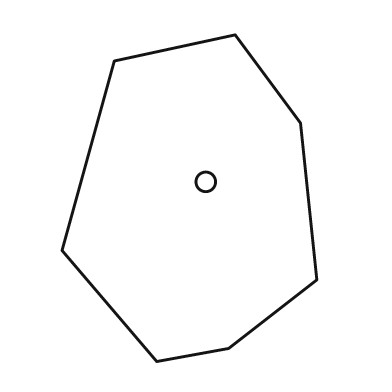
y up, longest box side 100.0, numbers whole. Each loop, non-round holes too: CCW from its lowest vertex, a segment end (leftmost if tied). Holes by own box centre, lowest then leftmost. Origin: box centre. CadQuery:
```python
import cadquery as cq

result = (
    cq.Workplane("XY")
    .moveTo(-10.0, -50.0)
    .lineTo(12.0, -46.0)
    .lineTo(39.0, -25.0)
    .lineTo(34.0, 23.0)
    .lineTo(14.0, 50.0)
    .lineTo(-23.0, 42.0)
    .lineTo(-39.0, -16.0)
    .close()
    .moveTo(5.0, 5.0)
    .circle(3.0)
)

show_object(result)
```